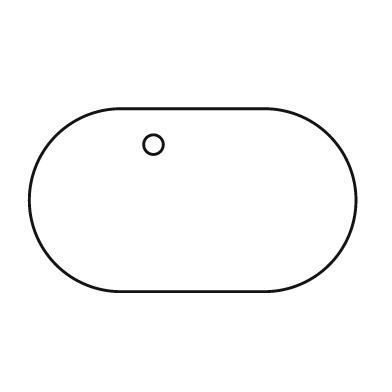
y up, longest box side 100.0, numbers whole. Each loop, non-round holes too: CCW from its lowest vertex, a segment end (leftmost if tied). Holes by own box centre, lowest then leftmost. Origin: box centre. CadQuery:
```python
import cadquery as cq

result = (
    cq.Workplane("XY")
    .moveTo(-22.0, -28.0)
    .lineTo(22.0, -28.0)
    .threePointArc((50.0, 0.0), (22.0, 28.0))
    .lineTo(-22.0, 28.0)
    .threePointArc((-50.0, 0.0), (-22.0, -28.0))
    .close()
    .moveTo(-12.0, 17.0)
    .circle(3.0)
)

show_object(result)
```